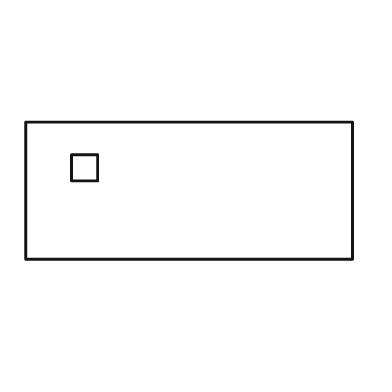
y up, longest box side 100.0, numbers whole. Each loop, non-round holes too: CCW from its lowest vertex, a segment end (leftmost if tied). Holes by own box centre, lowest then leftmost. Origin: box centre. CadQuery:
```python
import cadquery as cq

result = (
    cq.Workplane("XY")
    .moveTo(-50.0, -21.0)
    .lineTo(50.0, -21.0)
    .lineTo(50.0, 21.0)
    .lineTo(-50.0, 21.0)
    .close()
    .moveTo(-36.0, 3.0)
    .lineTo(-28.0, 3.0)
    .lineTo(-28.0, 11.0)
    .lineTo(-36.0, 11.0)
    .close()
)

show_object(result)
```